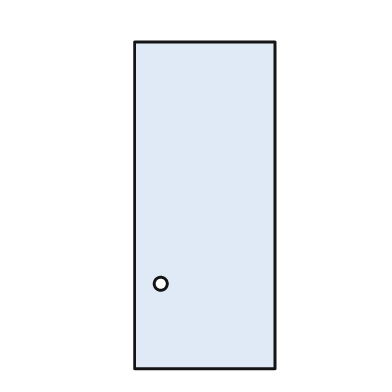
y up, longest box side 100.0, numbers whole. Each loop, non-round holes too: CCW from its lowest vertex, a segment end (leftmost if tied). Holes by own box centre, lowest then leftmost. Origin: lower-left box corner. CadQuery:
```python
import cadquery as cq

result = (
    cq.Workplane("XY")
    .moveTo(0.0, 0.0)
    .lineTo(43.0, 0.0)
    .lineTo(43.0, 100.0)
    .lineTo(0.0, 100.0)
    .close()
    .moveTo(8.0, 26.0)
    .circle(2.0)
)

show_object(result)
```